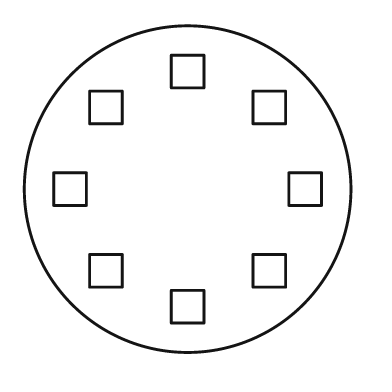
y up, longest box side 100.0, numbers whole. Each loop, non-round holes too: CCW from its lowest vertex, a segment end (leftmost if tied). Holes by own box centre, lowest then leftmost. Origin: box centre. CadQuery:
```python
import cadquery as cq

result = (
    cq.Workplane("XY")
    .moveTo(0.0, 0.0)
    .circle(50.0)
    .moveTo(-5.0, -41.0)
    .lineTo(5.0, -41.0)
    .lineTo(5.0, -31.0)
    .lineTo(-5.0, -31.0)
    .close()
    .moveTo(-30.0, -30.0)
    .lineTo(-20.0, -30.0)
    .lineTo(-20.0, -20.0)
    .lineTo(-30.0, -20.0)
    .close()
    .moveTo(20.0, -30.0)
    .lineTo(30.0, -30.0)
    .lineTo(30.0, -20.0)
    .lineTo(20.0, -20.0)
    .close()
    .moveTo(-41.0, -5.0)
    .lineTo(-31.0, -5.0)
    .lineTo(-31.0, 5.0)
    .lineTo(-41.0, 5.0)
    .close()
    .moveTo(31.0, -5.0)
    .lineTo(41.0, -5.0)
    .lineTo(41.0, 5.0)
    .lineTo(31.0, 5.0)
    .close()
    .moveTo(-30.0, 20.0)
    .lineTo(-20.0, 20.0)
    .lineTo(-20.0, 30.0)
    .lineTo(-30.0, 30.0)
    .close()
    .moveTo(20.0, 20.0)
    .lineTo(30.0, 20.0)
    .lineTo(30.0, 30.0)
    .lineTo(20.0, 30.0)
    .close()
    .moveTo(-5.0, 31.0)
    .lineTo(5.0, 31.0)
    .lineTo(5.0, 41.0)
    .lineTo(-5.0, 41.0)
    .close()
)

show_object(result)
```